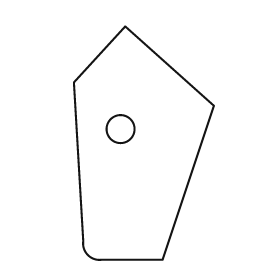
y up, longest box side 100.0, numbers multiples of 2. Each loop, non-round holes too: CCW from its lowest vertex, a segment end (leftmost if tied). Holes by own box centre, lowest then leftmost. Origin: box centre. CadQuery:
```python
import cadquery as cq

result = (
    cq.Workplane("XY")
    .moveTo(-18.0, -50.0)
    .lineTo(8.0, -50.0)
    .lineTo(30.0, 16.0)
    .lineTo(-8.0, 50.0)
    .lineTo(-30.0, 26.0)
    .lineTo(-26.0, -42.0)
    .threePointArc((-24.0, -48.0), (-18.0, -50.0))
    .close()
    .moveTo(-10.0, 6.0)
    .circle(6.0)
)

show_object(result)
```